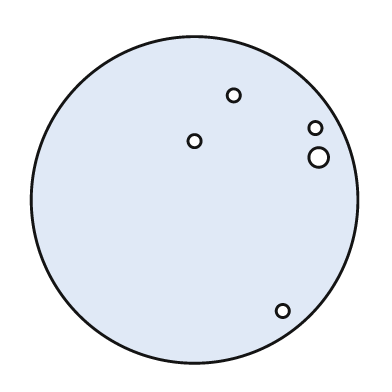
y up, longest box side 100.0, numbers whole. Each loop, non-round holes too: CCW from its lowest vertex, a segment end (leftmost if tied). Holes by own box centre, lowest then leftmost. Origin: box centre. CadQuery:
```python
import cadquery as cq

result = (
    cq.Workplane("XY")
    .moveTo(0.0, 0.0)
    .circle(50.0)
    .moveTo(27.0, -34.0)
    .circle(2.0)
    .moveTo(38.0, 13.0)
    .circle(3.0)
    .moveTo(0.0, 18.0)
    .circle(2.0)
    .moveTo(37.0, 22.0)
    .circle(2.0)
    .moveTo(12.0, 32.0)
    .circle(2.0)
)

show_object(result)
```